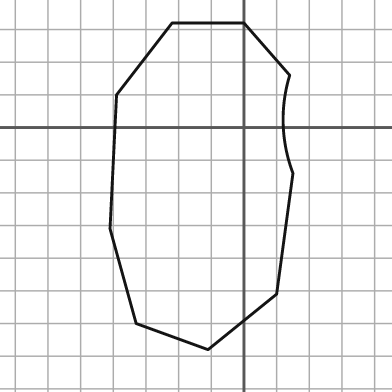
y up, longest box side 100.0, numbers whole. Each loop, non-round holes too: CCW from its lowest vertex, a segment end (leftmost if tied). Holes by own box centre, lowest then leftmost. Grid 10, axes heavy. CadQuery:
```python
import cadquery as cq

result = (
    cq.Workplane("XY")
    .moveTo(-11.0, -68.0)
    .lineTo(10.0, -51.0)
    .lineTo(15.0, -14.0)
    .threePointArc((12.0, 1.0), (14.0, 16.0))
    .lineTo(0.0, 32.0)
    .lineTo(-22.0, 32.0)
    .lineTo(-39.0, 10.0)
    .lineTo(-41.0, -31.0)
    .lineTo(-33.0, -60.0)
    .close()
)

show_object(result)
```